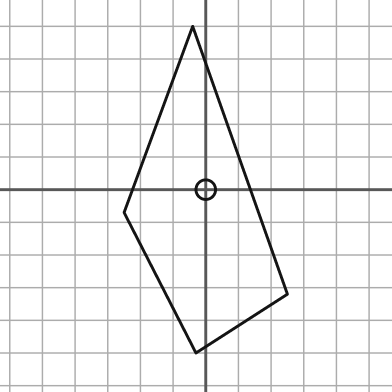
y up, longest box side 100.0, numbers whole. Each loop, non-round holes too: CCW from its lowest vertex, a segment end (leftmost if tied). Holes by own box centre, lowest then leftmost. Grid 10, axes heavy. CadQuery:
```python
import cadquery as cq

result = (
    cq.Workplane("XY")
    .moveTo(-3.0, -50.0)
    .lineTo(25.0, -32.0)
    .lineTo(-4.0, 50.0)
    .lineTo(-25.0, -7.0)
    .close()
    .moveTo(0.0, 0.0)
    .circle(3.0)
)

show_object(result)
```